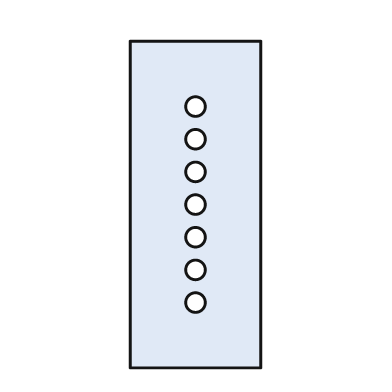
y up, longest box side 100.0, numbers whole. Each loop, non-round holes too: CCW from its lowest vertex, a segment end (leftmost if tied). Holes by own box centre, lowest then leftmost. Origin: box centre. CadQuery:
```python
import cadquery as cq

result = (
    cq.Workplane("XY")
    .moveTo(-20.0, -50.0)
    .lineTo(20.0, -50.0)
    .lineTo(20.0, 50.0)
    .lineTo(-20.0, 50.0)
    .close()
    .moveTo(0.0, -30.0)
    .circle(3.0)
    .moveTo(0.0, -20.0)
    .circle(3.0)
    .moveTo(0.0, -10.0)
    .circle(3.0)
    .moveTo(0.0, 0.0)
    .circle(3.0)
    .moveTo(0.0, 10.0)
    .circle(3.0)
    .moveTo(0.0, 20.0)
    .circle(3.0)
    .moveTo(0.0, 30.0)
    .circle(3.0)
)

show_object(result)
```